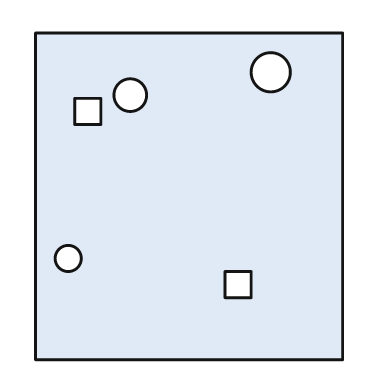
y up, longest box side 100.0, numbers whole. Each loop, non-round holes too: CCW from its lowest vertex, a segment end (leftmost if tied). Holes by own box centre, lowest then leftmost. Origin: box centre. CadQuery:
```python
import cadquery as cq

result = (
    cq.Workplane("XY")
    .moveTo(-47.0, -50.0)
    .lineTo(47.0, -50.0)
    .lineTo(47.0, 50.0)
    .lineTo(-47.0, 50.0)
    .close()
    .moveTo(11.0, -31.0)
    .lineTo(19.0, -31.0)
    .lineTo(19.0, -23.0)
    .lineTo(11.0, -23.0)
    .close()
    .moveTo(-37.0, -19.0)
    .circle(4.0)
    .moveTo(-35.0, 22.0)
    .lineTo(-27.0, 22.0)
    .lineTo(-27.0, 30.0)
    .lineTo(-35.0, 30.0)
    .close()
    .moveTo(-18.0, 31.0)
    .circle(5.0)
    .moveTo(25.0, 38.0)
    .circle(6.0)
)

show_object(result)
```